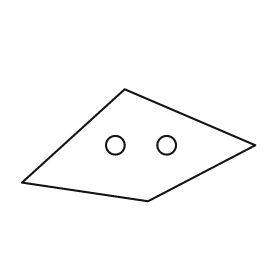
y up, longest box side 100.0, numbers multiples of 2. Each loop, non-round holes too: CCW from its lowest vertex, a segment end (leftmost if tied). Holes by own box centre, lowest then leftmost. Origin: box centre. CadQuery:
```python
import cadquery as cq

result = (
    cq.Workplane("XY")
    .moveTo(4.0, -24.0)
    .lineTo(50.0, 0.0)
    .lineTo(-6.0, 24.0)
    .lineTo(-50.0, -16.0)
    .close()
    .moveTo(-10.0, 0.0)
    .circle(4.0)
    .moveTo(12.0, 0.0)
    .circle(4.0)
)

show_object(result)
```